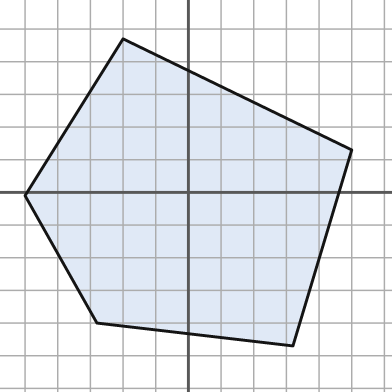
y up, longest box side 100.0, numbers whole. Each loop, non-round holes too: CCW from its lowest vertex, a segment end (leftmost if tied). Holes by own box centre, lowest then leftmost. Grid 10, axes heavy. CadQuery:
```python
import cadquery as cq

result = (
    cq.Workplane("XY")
    .moveTo(32.0, -47.0)
    .lineTo(50.0, 13.0)
    .lineTo(-20.0, 47.0)
    .lineTo(-50.0, -1.0)
    .lineTo(-28.0, -40.0)
    .close()
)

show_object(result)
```